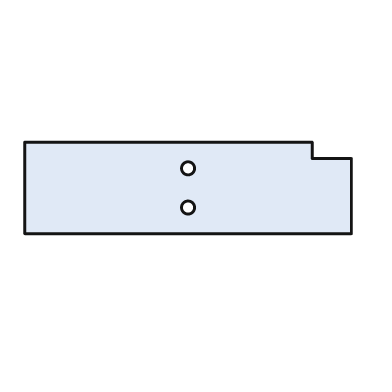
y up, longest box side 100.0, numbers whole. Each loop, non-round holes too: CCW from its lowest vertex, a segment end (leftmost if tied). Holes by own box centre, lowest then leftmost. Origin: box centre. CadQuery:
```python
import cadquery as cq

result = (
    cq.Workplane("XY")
    .moveTo(-50.0, -14.0)
    .lineTo(50.0, -14.0)
    .lineTo(50.0, 9.0)
    .lineTo(38.0, 9.0)
    .lineTo(38.0, 14.0)
    .lineTo(-50.0, 14.0)
    .close()
    .moveTo(0.0, -6.0)
    .circle(2.0)
    .moveTo(0.0, 6.0)
    .circle(2.0)
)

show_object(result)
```